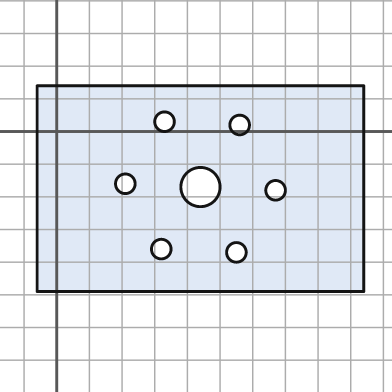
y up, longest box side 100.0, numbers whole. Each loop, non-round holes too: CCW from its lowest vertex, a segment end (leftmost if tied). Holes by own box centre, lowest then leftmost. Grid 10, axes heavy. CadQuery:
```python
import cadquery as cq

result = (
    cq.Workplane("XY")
    .moveTo(-6.0, -49.0)
    .lineTo(94.0, -49.0)
    .lineTo(94.0, 14.0)
    .lineTo(-6.0, 14.0)
    .close()
    .moveTo(55.0, -37.0)
    .circle(3.0)
    .moveTo(32.0, -36.0)
    .circle(3.0)
    .moveTo(67.0, -18.0)
    .circle(3.0)
    .moveTo(44.0, -17.0)
    .circle(6.0)
    .moveTo(21.0, -16.0)
    .circle(3.0)
    .moveTo(56.0, 2.0)
    .circle(3.0)
    .moveTo(33.0, 3.0)
    .circle(3.0)
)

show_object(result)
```